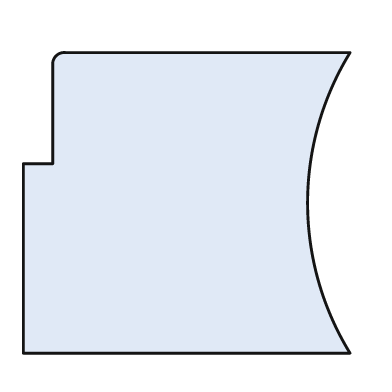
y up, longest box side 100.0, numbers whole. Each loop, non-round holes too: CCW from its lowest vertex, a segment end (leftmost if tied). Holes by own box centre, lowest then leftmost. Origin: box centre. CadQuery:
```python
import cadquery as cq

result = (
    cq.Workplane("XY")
    .moveTo(-50.0, -46.0)
    .lineTo(50.0, -46.0)
    .threePointArc((37.0, 0.0), (50.0, 46.0))
    .lineTo(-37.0, 46.0)
    .threePointArc((-40.0, 45.0), (-41.0, 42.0))
    .lineTo(-41.0, 12.0)
    .lineTo(-50.0, 12.0)
    .close()
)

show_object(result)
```